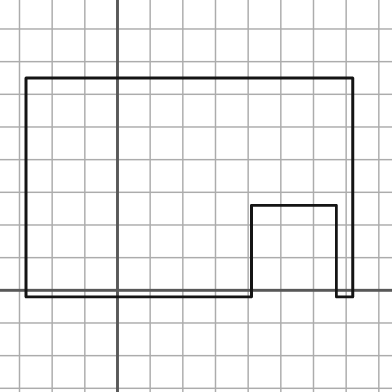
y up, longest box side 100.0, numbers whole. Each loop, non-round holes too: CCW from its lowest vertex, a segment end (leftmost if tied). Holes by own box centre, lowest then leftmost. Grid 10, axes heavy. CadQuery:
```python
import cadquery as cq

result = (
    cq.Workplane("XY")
    .moveTo(-28.0, -2.0)
    .lineTo(41.0, -2.0)
    .lineTo(41.0, 26.0)
    .lineTo(67.0, 26.0)
    .lineTo(67.0, -2.0)
    .lineTo(72.0, -2.0)
    .lineTo(72.0, 65.0)
    .lineTo(-28.0, 65.0)
    .close()
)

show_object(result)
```